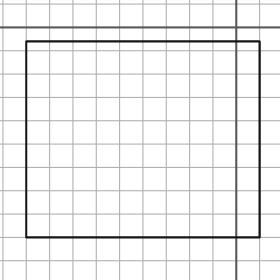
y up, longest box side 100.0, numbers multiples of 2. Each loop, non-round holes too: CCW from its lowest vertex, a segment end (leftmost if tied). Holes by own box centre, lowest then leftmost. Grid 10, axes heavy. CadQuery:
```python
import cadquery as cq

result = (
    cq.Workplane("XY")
    .moveTo(-90.0, -90.0)
    .lineTo(10.0, -90.0)
    .lineTo(10.0, -6.0)
    .lineTo(-90.0, -6.0)
    .close()
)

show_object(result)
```